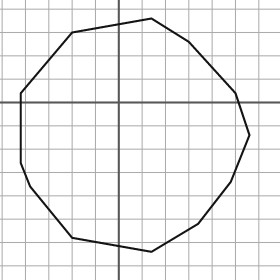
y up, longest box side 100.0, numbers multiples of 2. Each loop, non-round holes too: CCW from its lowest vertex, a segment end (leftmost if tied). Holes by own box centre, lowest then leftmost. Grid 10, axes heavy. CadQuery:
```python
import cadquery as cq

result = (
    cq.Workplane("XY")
    .moveTo(14.0, -64.0)
    .lineTo(34.0, -52.0)
    .lineTo(48.0, -34.0)
    .lineTo(56.0, -14.0)
    .lineTo(50.0, 4.0)
    .lineTo(30.0, 26.0)
    .lineTo(14.0, 36.0)
    .lineTo(-20.0, 30.0)
    .lineTo(-42.0, 4.0)
    .lineTo(-42.0, -26.0)
    .lineTo(-38.0, -36.0)
    .lineTo(-20.0, -58.0)
    .close()
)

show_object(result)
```